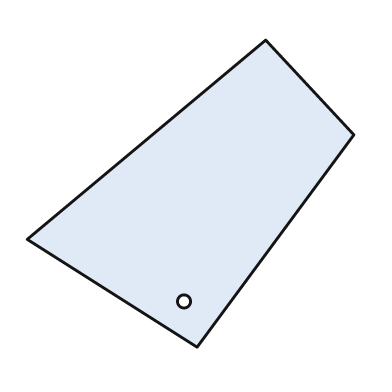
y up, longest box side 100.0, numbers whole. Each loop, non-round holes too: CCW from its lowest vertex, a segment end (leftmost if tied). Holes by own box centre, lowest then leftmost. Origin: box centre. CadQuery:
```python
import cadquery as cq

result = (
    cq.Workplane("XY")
    .moveTo(2.0, -47.0)
    .lineTo(50.0, 18.0)
    .lineTo(23.0, 47.0)
    .lineTo(-50.0, -14.0)
    .close()
    .moveTo(-2.0, -33.0)
    .circle(2.0)
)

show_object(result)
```